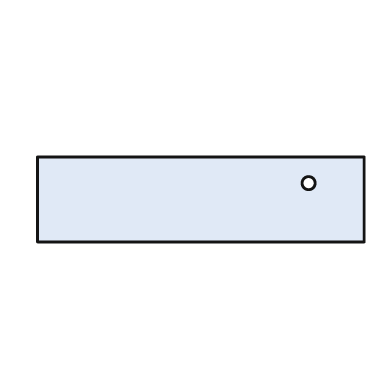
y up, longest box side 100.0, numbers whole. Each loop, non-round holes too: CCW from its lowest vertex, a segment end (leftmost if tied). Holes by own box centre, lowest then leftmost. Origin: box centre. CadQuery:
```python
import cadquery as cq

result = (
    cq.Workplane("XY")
    .moveTo(-50.0, -13.0)
    .lineTo(50.0, -13.0)
    .lineTo(50.0, 13.0)
    .lineTo(-50.0, 13.0)
    .close()
    .moveTo(33.0, 5.0)
    .circle(2.0)
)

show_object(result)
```